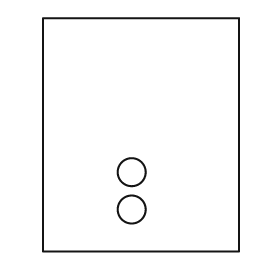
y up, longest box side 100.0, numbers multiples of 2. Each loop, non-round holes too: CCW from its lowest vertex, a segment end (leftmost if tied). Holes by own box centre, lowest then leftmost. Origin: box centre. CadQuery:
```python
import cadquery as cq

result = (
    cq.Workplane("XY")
    .moveTo(-42.0, -50.0)
    .lineTo(42.0, -50.0)
    .lineTo(42.0, 50.0)
    .lineTo(-42.0, 50.0)
    .close()
    .moveTo(-4.0, -32.0)
    .circle(6.0)
    .moveTo(-4.0, -16.0)
    .circle(6.0)
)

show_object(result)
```